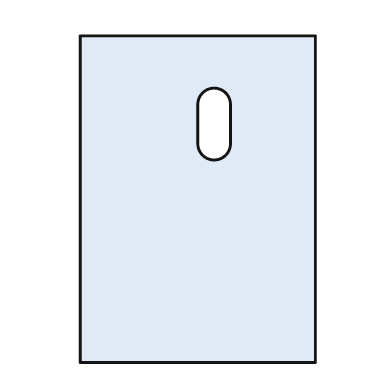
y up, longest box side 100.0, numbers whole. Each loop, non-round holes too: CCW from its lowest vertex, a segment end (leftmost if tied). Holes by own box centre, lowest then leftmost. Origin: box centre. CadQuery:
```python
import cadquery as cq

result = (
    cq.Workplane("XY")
    .moveTo(-36.0, -50.0)
    .lineTo(36.0, -50.0)
    .lineTo(36.0, 50.0)
    .lineTo(-36.0, 50.0)
    .close()
    .moveTo(0.0, 17.0)
    .threePointArc((5.0, 12.0), (10.0, 17.0))
    .lineTo(10.0, 29.0)
    .threePointArc((5.0, 34.0), (0.0, 29.0))
    .close()
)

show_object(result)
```